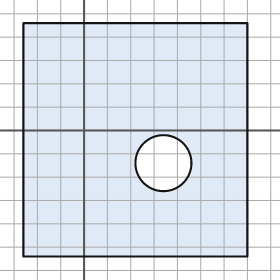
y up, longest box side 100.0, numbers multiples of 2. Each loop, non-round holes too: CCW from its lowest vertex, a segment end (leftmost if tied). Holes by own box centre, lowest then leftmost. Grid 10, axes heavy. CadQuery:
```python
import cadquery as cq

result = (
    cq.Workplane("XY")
    .moveTo(-26.0, -54.0)
    .lineTo(70.0, -54.0)
    .lineTo(70.0, 46.0)
    .lineTo(-26.0, 46.0)
    .close()
    .moveTo(34.0, -14.0)
    .circle(12.0)
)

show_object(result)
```